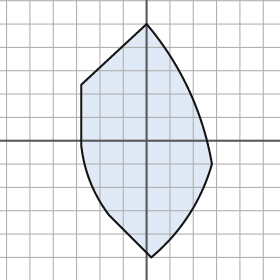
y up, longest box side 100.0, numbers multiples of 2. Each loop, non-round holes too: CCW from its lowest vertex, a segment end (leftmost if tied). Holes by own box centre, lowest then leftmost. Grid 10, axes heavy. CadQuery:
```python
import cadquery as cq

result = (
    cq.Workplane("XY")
    .moveTo(2.0, -50.0)
    .threePointArc((18.0, -32.0), (28.0, -10.0))
    .threePointArc((18.0, 22.0), (0.0, 50.0))
    .lineTo(-28.0, 24.0)
    .lineTo(-28.0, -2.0)
    .threePointArc((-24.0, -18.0), (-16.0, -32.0))
    .close()
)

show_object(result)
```